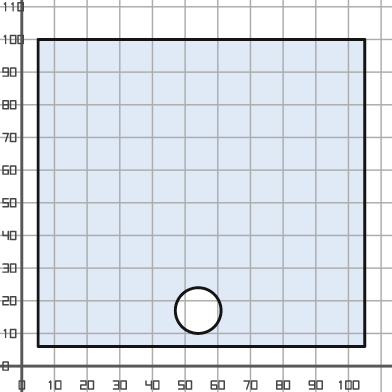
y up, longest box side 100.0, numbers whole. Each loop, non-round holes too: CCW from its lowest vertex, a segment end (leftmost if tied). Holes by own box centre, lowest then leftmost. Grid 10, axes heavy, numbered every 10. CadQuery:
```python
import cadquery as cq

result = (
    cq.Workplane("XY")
    .moveTo(5.0, 6.0)
    .lineTo(105.0, 6.0)
    .lineTo(105.0, 100.0)
    .lineTo(5.0, 100.0)
    .close()
    .moveTo(54.0, 17.0)
    .circle(7.0)
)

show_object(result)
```